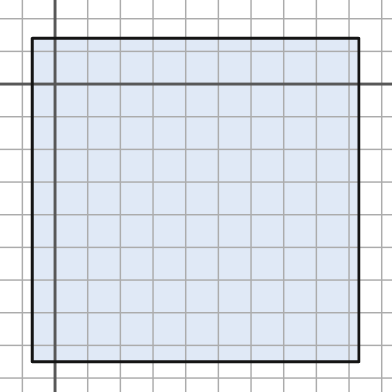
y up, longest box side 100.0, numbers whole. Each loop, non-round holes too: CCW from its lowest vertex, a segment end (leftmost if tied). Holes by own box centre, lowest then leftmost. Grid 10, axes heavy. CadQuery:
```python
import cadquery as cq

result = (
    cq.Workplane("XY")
    .moveTo(-7.0, -85.0)
    .lineTo(93.0, -85.0)
    .lineTo(93.0, 14.0)
    .lineTo(-7.0, 14.0)
    .close()
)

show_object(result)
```